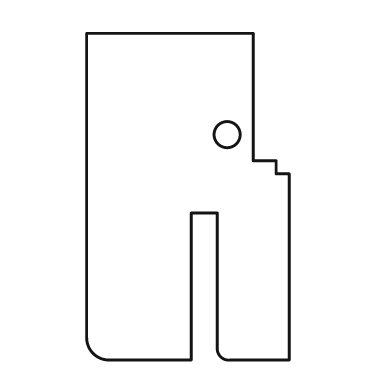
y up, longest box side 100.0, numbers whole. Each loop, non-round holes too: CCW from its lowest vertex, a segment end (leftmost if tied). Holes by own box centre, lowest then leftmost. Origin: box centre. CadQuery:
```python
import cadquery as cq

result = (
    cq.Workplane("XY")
    .moveTo(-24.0, -50.0)
    .lineTo(1.0, -50.0)
    .lineTo(1.0, -5.0)
    .lineTo(9.0, -5.0)
    .lineTo(9.0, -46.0)
    .threePointArc((10.0, -49.0), (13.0, -50.0))
    .lineTo(31.0, -50.0)
    .lineTo(31.0, 7.0)
    .lineTo(27.0, 7.0)
    .lineTo(27.0, 11.0)
    .lineTo(20.0, 11.0)
    .lineTo(20.0, 50.0)
    .lineTo(-31.0, 50.0)
    .lineTo(-31.0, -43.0)
    .threePointArc((-29.0, -48.0), (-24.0, -50.0))
    .close()
    .moveTo(12.0, 19.0)
    .circle(4.0)
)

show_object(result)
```